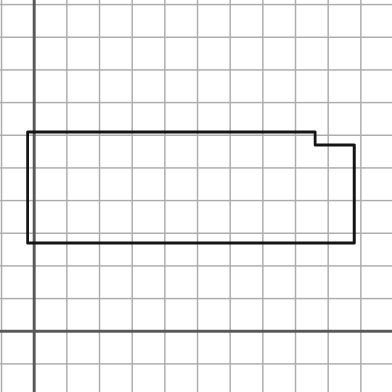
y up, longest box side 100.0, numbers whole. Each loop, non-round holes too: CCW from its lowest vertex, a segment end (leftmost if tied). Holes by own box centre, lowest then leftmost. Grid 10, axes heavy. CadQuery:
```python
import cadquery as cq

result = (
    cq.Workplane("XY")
    .moveTo(-2.0, 27.0)
    .lineTo(98.0, 27.0)
    .lineTo(98.0, 57.0)
    .lineTo(86.0, 57.0)
    .lineTo(86.0, 61.0)
    .lineTo(-2.0, 61.0)
    .close()
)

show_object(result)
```